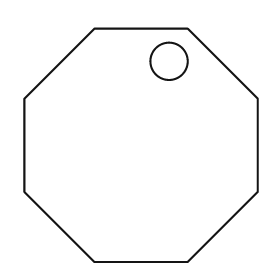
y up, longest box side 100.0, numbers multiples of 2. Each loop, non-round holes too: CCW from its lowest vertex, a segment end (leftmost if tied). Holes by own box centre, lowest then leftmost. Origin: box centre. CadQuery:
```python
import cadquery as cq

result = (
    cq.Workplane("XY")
    .moveTo(-20.0, -50.0)
    .lineTo(20.0, -50.0)
    .lineTo(50.0, -20.0)
    .lineTo(50.0, 20.0)
    .lineTo(20.0, 50.0)
    .lineTo(-20.0, 50.0)
    .lineTo(-50.0, 20.0)
    .lineTo(-50.0, -20.0)
    .close()
    .moveTo(12.0, 36.0)
    .circle(8.0)
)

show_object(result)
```